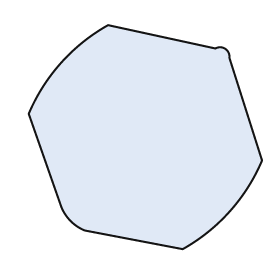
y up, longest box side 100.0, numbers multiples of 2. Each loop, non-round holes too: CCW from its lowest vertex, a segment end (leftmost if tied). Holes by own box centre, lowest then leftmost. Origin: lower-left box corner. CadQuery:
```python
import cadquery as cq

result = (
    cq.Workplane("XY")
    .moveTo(66.0, 0.0)
    .threePointArc((86.0, 16.0), (100.0, 38.0))
    .lineTo(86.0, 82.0)
    .threePointArc((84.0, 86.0), (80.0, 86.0))
    .lineTo(34.0, 96.0)
    .threePointArc((14.0, 80.0), (0.0, 58.0))
    .lineTo(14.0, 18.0)
    .threePointArc((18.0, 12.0), (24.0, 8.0))
    .close()
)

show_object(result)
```